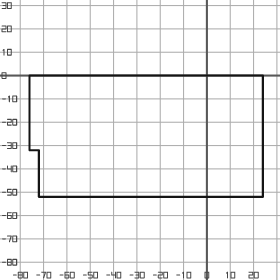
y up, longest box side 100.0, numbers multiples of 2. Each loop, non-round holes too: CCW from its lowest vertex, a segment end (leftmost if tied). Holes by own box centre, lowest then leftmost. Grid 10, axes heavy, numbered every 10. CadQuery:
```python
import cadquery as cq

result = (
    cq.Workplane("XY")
    .moveTo(-72.0, -52.0)
    .lineTo(24.0, -52.0)
    .lineTo(24.0, 0.0)
    .lineTo(-76.0, 0.0)
    .lineTo(-76.0, -32.0)
    .lineTo(-72.0, -32.0)
    .close()
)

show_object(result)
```